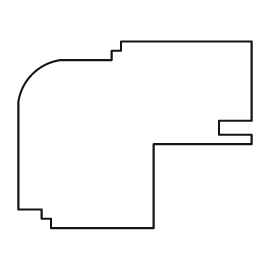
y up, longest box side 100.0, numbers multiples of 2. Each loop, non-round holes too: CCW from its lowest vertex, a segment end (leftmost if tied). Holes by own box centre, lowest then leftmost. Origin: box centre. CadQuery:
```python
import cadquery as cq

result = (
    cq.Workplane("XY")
    .moveTo(-36.0, -40.0)
    .lineTo(8.0, -40.0)
    .lineTo(8.0, -4.0)
    .lineTo(50.0, -4.0)
    .lineTo(50.0, 0.0)
    .lineTo(36.0, 0.0)
    .lineTo(36.0, 6.0)
    .lineTo(50.0, 6.0)
    .lineTo(50.0, 40.0)
    .lineTo(-6.0, 40.0)
    .lineTo(-6.0, 36.0)
    .lineTo(-10.0, 36.0)
    .lineTo(-10.0, 32.0)
    .lineTo(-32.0, 32.0)
    .threePointArc((-44.0, 26.0), (-50.0, 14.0))
    .lineTo(-50.0, -32.0)
    .lineTo(-40.0, -32.0)
    .lineTo(-40.0, -36.0)
    .lineTo(-36.0, -36.0)
    .close()
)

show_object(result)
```